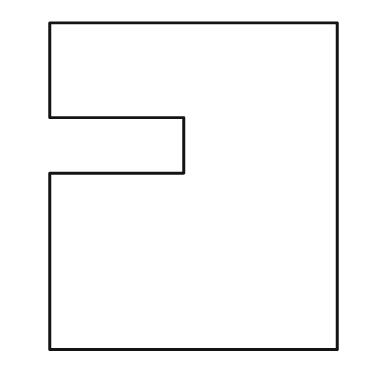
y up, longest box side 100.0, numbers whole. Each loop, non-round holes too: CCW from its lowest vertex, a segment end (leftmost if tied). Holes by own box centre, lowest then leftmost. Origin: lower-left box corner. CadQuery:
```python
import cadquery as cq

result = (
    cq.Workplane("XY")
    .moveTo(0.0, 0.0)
    .lineTo(88.0, 0.0)
    .lineTo(88.0, 100.0)
    .lineTo(0.0, 100.0)
    .lineTo(0.0, 71.0)
    .lineTo(41.0, 71.0)
    .lineTo(41.0, 54.0)
    .lineTo(0.0, 54.0)
    .close()
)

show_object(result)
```